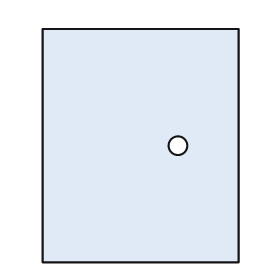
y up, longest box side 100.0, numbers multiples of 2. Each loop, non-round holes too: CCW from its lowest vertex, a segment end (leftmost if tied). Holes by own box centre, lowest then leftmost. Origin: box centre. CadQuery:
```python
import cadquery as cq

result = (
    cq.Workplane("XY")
    .moveTo(-42.0, -50.0)
    .lineTo(42.0, -50.0)
    .lineTo(42.0, 50.0)
    .lineTo(-42.0, 50.0)
    .close()
    .moveTo(16.0, 0.0)
    .circle(4.0)
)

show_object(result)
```